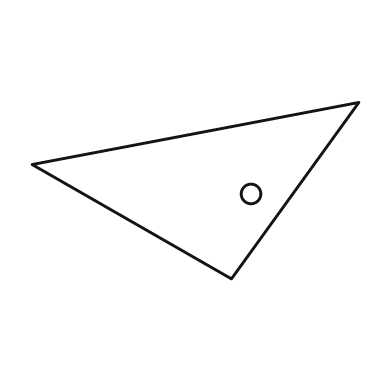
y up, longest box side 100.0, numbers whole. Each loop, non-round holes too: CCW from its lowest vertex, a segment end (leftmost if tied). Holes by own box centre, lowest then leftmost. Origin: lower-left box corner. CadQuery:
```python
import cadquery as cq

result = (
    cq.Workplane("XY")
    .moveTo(61.0, 0.0)
    .lineTo(100.0, 54.0)
    .lineTo(0.0, 35.0)
    .close()
    .moveTo(67.0, 26.0)
    .circle(3.0)
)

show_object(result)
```